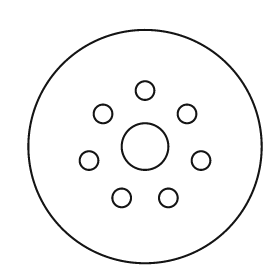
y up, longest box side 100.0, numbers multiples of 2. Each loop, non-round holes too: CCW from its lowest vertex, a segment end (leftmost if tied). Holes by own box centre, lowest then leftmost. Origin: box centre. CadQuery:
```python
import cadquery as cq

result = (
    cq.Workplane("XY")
    .moveTo(0.0, 0.0)
    .circle(50.0)
    .moveTo(-10.0, -22.0)
    .circle(4.0)
    .moveTo(10.0, -22.0)
    .circle(4.0)
    .moveTo(-24.0, -6.0)
    .circle(4.0)
    .moveTo(24.0, -6.0)
    .circle(4.0)
    .moveTo(0.0, 0.0)
    .circle(10.0)
    .moveTo(-18.0, 14.0)
    .circle(4.0)
    .moveTo(18.0, 14.0)
    .circle(4.0)
    .moveTo(0.0, 24.0)
    .circle(4.0)
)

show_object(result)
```